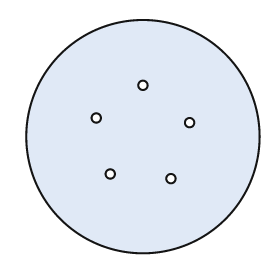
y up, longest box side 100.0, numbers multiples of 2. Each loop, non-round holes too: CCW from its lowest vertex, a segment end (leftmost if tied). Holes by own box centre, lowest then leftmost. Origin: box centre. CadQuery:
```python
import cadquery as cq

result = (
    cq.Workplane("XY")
    .moveTo(0.0, 0.0)
    .circle(50.0)
    .moveTo(12.0, -18.0)
    .circle(2.0)
    .moveTo(-14.0, -16.0)
    .circle(2.0)
    .moveTo(20.0, 6.0)
    .circle(2.0)
    .moveTo(-20.0, 8.0)
    .circle(2.0)
    .moveTo(0.0, 22.0)
    .circle(2.0)
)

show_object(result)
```